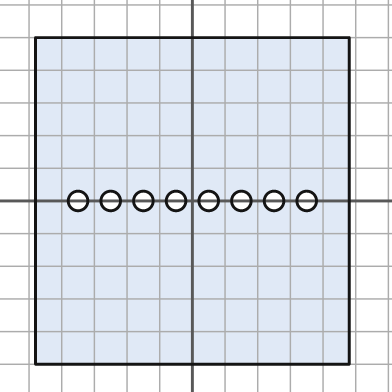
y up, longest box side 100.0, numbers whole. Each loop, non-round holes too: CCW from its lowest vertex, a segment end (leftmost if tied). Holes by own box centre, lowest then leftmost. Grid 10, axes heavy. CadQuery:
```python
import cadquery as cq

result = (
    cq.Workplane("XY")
    .moveTo(-48.0, -50.0)
    .lineTo(48.0, -50.0)
    .lineTo(48.0, 50.0)
    .lineTo(-48.0, 50.0)
    .close()
    .moveTo(-35.0, 0.0)
    .circle(3.0)
    .moveTo(-25.0, 0.0)
    .circle(3.0)
    .moveTo(-15.0, 0.0)
    .circle(3.0)
    .moveTo(-5.0, 0.0)
    .circle(3.0)
    .moveTo(5.0, 0.0)
    .circle(3.0)
    .moveTo(15.0, 0.0)
    .circle(3.0)
    .moveTo(25.0, 0.0)
    .circle(3.0)
    .moveTo(35.0, 0.0)
    .circle(3.0)
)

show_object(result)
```